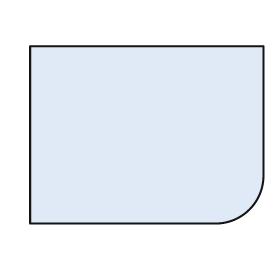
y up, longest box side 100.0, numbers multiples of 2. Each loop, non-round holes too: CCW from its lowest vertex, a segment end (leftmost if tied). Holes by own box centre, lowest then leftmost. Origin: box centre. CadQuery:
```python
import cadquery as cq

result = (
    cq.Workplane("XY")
    .moveTo(-50.0, -38.0)
    .lineTo(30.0, -38.0)
    .threePointArc((44.0, -32.0), (50.0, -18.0))
    .lineTo(50.0, 38.0)
    .lineTo(-50.0, 38.0)
    .close()
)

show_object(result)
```